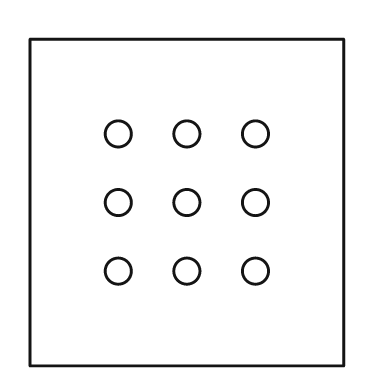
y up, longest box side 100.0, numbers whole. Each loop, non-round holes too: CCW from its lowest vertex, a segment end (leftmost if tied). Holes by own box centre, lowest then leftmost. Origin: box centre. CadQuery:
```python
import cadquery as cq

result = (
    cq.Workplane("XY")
    .moveTo(-48.0, -50.0)
    .lineTo(48.0, -50.0)
    .lineTo(48.0, 50.0)
    .lineTo(-48.0, 50.0)
    .close()
    .moveTo(-21.0, -21.0)
    .circle(4.0)
    .moveTo(0.0, -21.0)
    .circle(4.0)
    .moveTo(21.0, -21.0)
    .circle(4.0)
    .moveTo(-21.0, 0.0)
    .circle(4.0)
    .moveTo(0.0, 0.0)
    .circle(4.0)
    .moveTo(21.0, 0.0)
    .circle(4.0)
    .moveTo(-21.0, 21.0)
    .circle(4.0)
    .moveTo(0.0, 21.0)
    .circle(4.0)
    .moveTo(21.0, 21.0)
    .circle(4.0)
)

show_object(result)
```